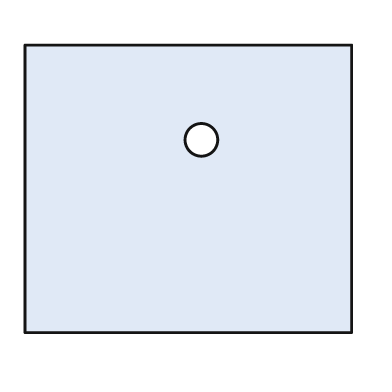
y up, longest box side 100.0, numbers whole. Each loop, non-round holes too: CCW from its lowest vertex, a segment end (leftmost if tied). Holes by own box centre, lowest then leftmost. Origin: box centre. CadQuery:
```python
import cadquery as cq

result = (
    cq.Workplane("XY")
    .moveTo(-50.0, -44.0)
    .lineTo(50.0, -44.0)
    .lineTo(50.0, 44.0)
    .lineTo(-50.0, 44.0)
    .close()
    .moveTo(4.0, 15.0)
    .circle(5.0)
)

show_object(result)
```